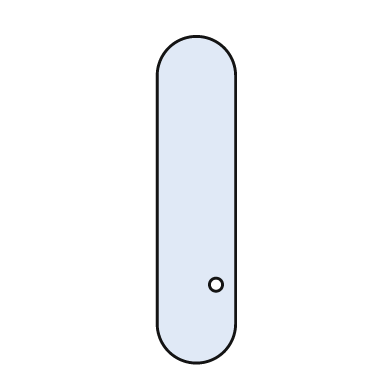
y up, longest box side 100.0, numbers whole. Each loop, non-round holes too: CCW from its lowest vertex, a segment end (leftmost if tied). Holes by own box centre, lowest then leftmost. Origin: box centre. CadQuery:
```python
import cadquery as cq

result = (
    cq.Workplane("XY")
    .moveTo(-12.0, -38.0)
    .threePointArc((0.0, -50.0), (12.0, -38.0))
    .lineTo(12.0, 38.0)
    .threePointArc((0.0, 50.0), (-12.0, 38.0))
    .close()
    .moveTo(6.0, -26.0)
    .circle(2.0)
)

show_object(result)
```